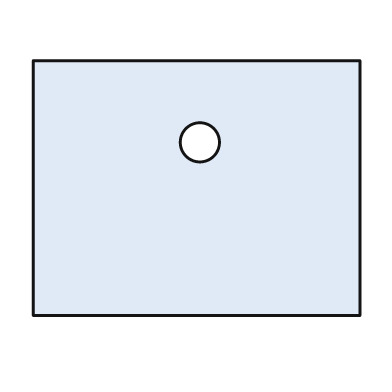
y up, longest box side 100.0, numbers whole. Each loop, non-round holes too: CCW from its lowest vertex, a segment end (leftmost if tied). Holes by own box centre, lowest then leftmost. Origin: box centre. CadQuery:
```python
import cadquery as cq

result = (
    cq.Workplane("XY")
    .moveTo(-50.0, -39.0)
    .lineTo(50.0, -39.0)
    .lineTo(50.0, 39.0)
    .lineTo(-50.0, 39.0)
    .close()
    .moveTo(1.0, 14.0)
    .circle(6.0)
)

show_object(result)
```